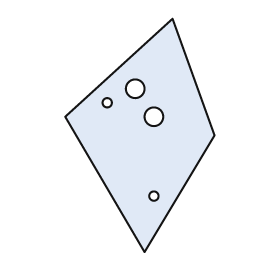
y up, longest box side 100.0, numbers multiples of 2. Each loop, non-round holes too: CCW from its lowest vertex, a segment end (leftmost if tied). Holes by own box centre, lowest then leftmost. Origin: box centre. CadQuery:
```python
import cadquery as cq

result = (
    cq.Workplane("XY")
    .moveTo(2.0, -50.0)
    .lineTo(32.0, 0.0)
    .lineTo(14.0, 50.0)
    .lineTo(-32.0, 8.0)
    .close()
    .moveTo(6.0, -26.0)
    .circle(2.0)
    .moveTo(6.0, 8.0)
    .circle(4.0)
    .moveTo(-14.0, 14.0)
    .circle(2.0)
    .moveTo(-2.0, 20.0)
    .circle(4.0)
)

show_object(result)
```